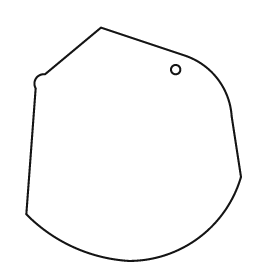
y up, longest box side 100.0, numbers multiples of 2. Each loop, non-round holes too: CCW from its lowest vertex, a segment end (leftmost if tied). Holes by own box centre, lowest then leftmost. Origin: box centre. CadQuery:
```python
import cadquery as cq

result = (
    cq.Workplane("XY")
    .moveTo(-2.0, -50.0)
    .threePointArc((28.0, -40.0), (46.0, -14.0))
    .lineTo(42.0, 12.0)
    .threePointArc((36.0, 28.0), (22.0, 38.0))
    .lineTo(-14.0, 50.0)
    .lineTo(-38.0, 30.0)
    .threePointArc((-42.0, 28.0), (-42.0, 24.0))
    .lineTo(-46.0, -30.0)
    .threePointArc((-26.0, -44.0), (-2.0, -50.0))
    .close()
    .moveTo(18.0, 32.0)
    .circle(2.0)
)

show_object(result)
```